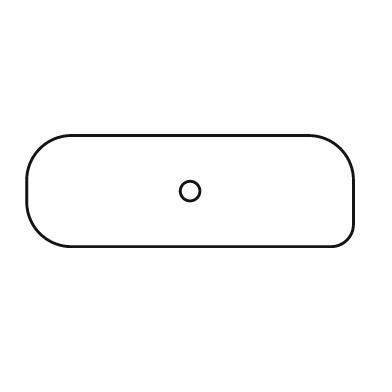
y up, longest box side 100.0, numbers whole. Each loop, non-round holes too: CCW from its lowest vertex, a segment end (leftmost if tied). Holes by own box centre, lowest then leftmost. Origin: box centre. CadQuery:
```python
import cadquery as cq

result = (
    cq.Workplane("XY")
    .moveTo(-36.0, -17.0)
    .lineTo(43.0, -17.0)
    .threePointArc((48.0, -15.0), (50.0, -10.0))
    .lineTo(50.0, 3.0)
    .threePointArc((46.0, 13.0), (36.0, 17.0))
    .lineTo(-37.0, 17.0)
    .threePointArc((-46.0, 13.0), (-50.0, 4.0))
    .lineTo(-50.0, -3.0)
    .threePointArc((-46.0, -13.0), (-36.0, -17.0))
    .close()
    .moveTo(0.0, 0.0)
    .circle(3.0)
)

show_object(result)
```